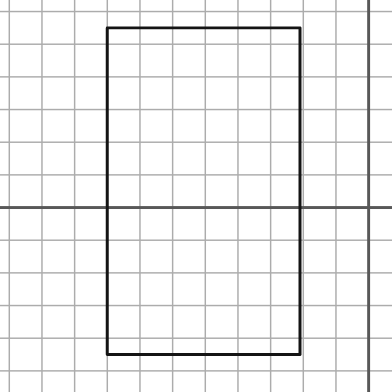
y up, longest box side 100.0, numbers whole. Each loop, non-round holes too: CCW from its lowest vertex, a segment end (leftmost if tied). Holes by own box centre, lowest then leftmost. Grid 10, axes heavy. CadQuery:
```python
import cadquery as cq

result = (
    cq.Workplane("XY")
    .moveTo(-80.0, -45.0)
    .lineTo(-21.0, -45.0)
    .lineTo(-21.0, 55.0)
    .lineTo(-80.0, 55.0)
    .close()
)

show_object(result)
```